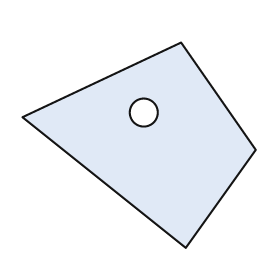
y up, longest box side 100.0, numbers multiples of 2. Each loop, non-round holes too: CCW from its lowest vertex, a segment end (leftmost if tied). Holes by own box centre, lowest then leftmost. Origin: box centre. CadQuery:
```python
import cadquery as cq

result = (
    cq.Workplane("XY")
    .moveTo(20.0, -44.0)
    .lineTo(50.0, -2.0)
    .lineTo(18.0, 44.0)
    .lineTo(-50.0, 12.0)
    .close()
    .moveTo(2.0, 14.0)
    .circle(6.0)
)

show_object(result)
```